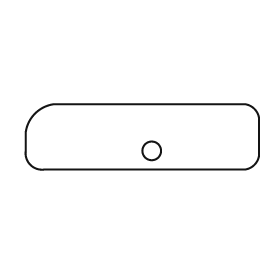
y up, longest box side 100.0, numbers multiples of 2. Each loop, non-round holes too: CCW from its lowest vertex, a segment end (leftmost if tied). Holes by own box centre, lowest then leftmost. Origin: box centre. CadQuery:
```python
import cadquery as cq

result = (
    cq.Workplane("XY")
    .moveTo(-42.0, -14.0)
    .lineTo(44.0, -14.0)
    .threePointArc((48.0, -12.0), (50.0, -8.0))
    .lineTo(50.0, 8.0)
    .threePointArc((48.0, 12.0), (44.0, 14.0))
    .lineTo(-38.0, 14.0)
    .threePointArc((-46.0, 10.0), (-50.0, 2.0))
    .lineTo(-50.0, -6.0)
    .threePointArc((-48.0, -12.0), (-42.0, -14.0))
    .close()
    .moveTo(4.0, -6.0)
    .circle(4.0)
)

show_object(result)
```